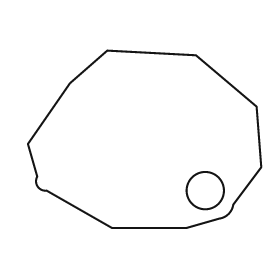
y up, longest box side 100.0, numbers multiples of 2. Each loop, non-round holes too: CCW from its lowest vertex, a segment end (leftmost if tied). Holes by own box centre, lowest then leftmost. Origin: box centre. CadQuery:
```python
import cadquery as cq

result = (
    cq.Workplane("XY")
    .moveTo(-14.0, -38.0)
    .lineTo(18.0, -38.0)
    .lineTo(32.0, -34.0)
    .threePointArc((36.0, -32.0), (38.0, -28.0))
    .lineTo(50.0, -12.0)
    .lineTo(48.0, 14.0)
    .lineTo(22.0, 36.0)
    .lineTo(-16.0, 38.0)
    .lineTo(-32.0, 24.0)
    .lineTo(-50.0, -2.0)
    .lineTo(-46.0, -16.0)
    .threePointArc((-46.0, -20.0), (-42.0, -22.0))
    .close()
    .moveTo(26.0, -22.0)
    .circle(8.0)
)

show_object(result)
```